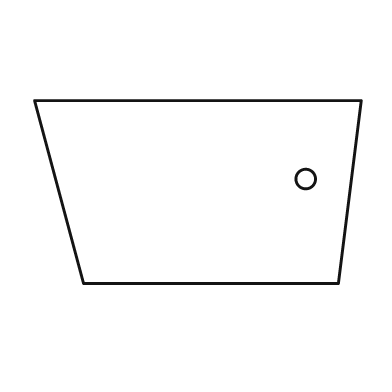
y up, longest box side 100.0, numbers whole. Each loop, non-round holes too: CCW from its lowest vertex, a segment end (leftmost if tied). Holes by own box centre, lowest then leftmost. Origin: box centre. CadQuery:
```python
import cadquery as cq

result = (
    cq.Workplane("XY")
    .moveTo(-35.0, -28.0)
    .lineTo(43.0, -28.0)
    .lineTo(50.0, 28.0)
    .lineTo(-50.0, 28.0)
    .close()
    .moveTo(33.0, 4.0)
    .circle(3.0)
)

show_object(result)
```